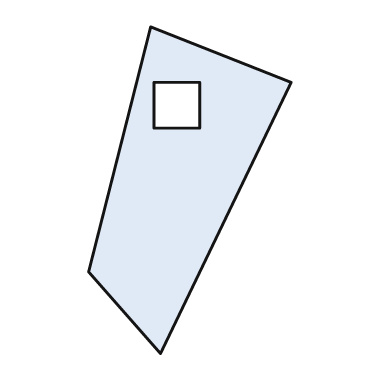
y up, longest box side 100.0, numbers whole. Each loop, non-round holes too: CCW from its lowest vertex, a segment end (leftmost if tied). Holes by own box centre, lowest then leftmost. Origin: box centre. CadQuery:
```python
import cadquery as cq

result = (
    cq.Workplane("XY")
    .moveTo(-9.0, -50.0)
    .lineTo(31.0, 33.0)
    .lineTo(-12.0, 50.0)
    .lineTo(-31.0, -25.0)
    .close()
    .moveTo(-11.0, 19.0)
    .lineTo(3.0, 19.0)
    .lineTo(3.0, 33.0)
    .lineTo(-11.0, 33.0)
    .close()
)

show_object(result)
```